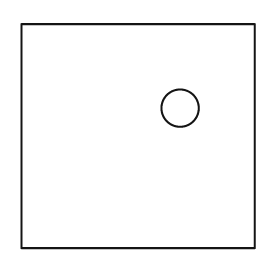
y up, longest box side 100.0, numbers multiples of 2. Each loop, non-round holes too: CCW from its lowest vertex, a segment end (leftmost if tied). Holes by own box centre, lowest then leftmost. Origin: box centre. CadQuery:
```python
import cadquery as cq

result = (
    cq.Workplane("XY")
    .moveTo(-50.0, -48.0)
    .lineTo(50.0, -48.0)
    .lineTo(50.0, 48.0)
    .lineTo(-50.0, 48.0)
    .close()
    .moveTo(18.0, 12.0)
    .circle(8.0)
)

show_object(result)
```